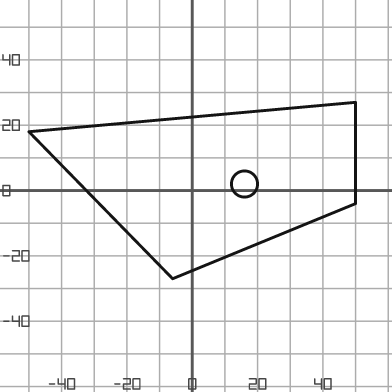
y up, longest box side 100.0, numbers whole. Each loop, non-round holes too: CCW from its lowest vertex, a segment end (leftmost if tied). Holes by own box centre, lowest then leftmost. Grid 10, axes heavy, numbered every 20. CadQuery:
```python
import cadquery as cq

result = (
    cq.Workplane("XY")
    .moveTo(-6.0, -27.0)
    .lineTo(50.0, -4.0)
    .lineTo(50.0, 27.0)
    .lineTo(-50.0, 18.0)
    .close()
    .moveTo(16.0, 2.0)
    .circle(4.0)
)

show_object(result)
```